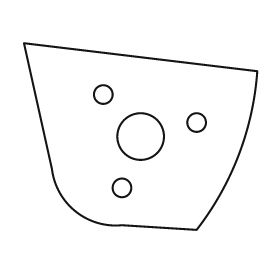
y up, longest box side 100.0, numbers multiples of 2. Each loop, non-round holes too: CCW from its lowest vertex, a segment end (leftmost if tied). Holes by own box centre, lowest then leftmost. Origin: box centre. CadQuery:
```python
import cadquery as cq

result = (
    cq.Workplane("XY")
    .moveTo(24.0, -40.0)
    .threePointArc((42.0, -8.0), (50.0, 28.0))
    .lineTo(-50.0, 40.0)
    .lineTo(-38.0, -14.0)
    .threePointArc((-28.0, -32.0), (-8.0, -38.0))
    .close()
    .moveTo(-8.0, -22.0)
    .circle(4.0)
    .moveTo(0.0, 0.0)
    .circle(10.0)
    .moveTo(24.0, 6.0)
    .circle(4.0)
    .moveTo(-16.0, 18.0)
    .circle(4.0)
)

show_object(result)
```